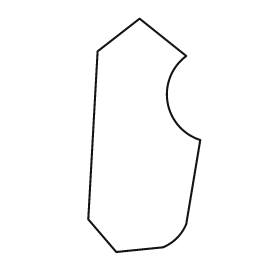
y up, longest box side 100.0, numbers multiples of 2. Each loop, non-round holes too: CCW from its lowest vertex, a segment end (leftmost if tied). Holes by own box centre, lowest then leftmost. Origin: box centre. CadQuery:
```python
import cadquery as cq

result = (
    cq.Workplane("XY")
    .moveTo(-12.0, -50.0)
    .lineTo(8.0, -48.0)
    .threePointArc((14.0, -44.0), (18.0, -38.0))
    .lineTo(24.0, -2.0)
    .threePointArc((10.0, 14.0), (18.0, 34.0))
    .lineTo(-2.0, 50.0)
    .lineTo(-20.0, 36.0)
    .lineTo(-24.0, -36.0)
    .close()
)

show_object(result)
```